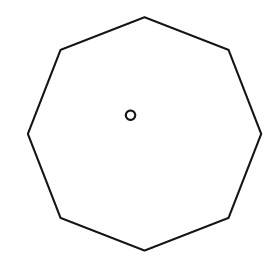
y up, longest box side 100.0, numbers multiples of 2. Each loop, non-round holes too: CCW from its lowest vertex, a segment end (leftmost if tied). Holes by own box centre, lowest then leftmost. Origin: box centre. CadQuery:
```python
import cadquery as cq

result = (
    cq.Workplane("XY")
    .moveTo(0.0, -50.0)
    .lineTo(36.0, -36.0)
    .lineTo(50.0, 0.0)
    .lineTo(36.0, 36.0)
    .lineTo(0.0, 50.0)
    .lineTo(-36.0, 36.0)
    .lineTo(-50.0, 0.0)
    .lineTo(-36.0, -36.0)
    .close()
    .moveTo(-6.0, 8.0)
    .circle(2.0)
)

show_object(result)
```